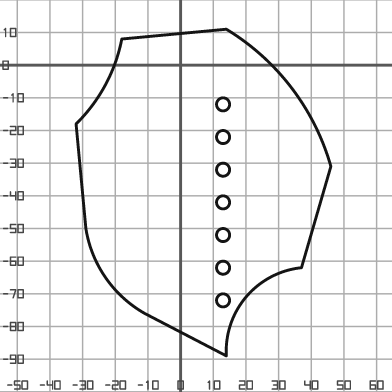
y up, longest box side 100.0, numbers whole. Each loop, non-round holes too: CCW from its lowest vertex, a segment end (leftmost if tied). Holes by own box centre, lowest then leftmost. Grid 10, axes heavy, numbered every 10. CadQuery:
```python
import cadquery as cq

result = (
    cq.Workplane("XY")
    .moveTo(14.0, -89.0)
    .threePointArc((20.0, -71.0), (37.0, -62.0))
    .lineTo(46.0, -31.0)
    .threePointArc((34.0, -7.0), (14.0, 11.0))
    .lineTo(-18.0, 8.0)
    .threePointArc((-23.0, -6.0), (-32.0, -18.0))
    .lineTo(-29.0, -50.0)
    .threePointArc((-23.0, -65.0), (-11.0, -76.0))
    .close()
    .moveTo(13.0, -72.0)
    .circle(2.0)
    .moveTo(13.0, -62.0)
    .circle(2.0)
    .moveTo(13.0, -52.0)
    .circle(2.0)
    .moveTo(13.0, -42.0)
    .circle(2.0)
    .moveTo(13.0, -32.0)
    .circle(2.0)
    .moveTo(13.0, -22.0)
    .circle(2.0)
    .moveTo(13.0, -12.0)
    .circle(2.0)
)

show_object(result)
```